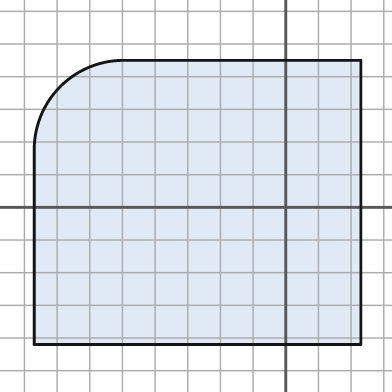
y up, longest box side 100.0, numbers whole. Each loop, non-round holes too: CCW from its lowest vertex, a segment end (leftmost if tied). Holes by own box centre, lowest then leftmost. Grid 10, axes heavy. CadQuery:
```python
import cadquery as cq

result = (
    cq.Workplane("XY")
    .moveTo(-77.0, -42.0)
    .lineTo(23.0, -42.0)
    .lineTo(23.0, 45.0)
    .lineTo(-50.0, 45.0)
    .threePointArc((-69.0, 37.0), (-77.0, 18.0))
    .close()
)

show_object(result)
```